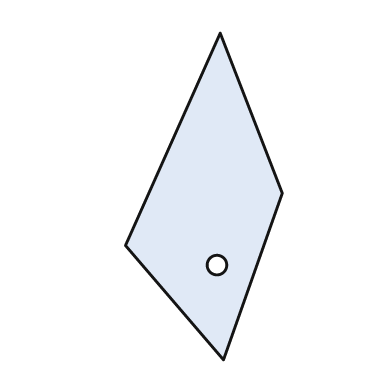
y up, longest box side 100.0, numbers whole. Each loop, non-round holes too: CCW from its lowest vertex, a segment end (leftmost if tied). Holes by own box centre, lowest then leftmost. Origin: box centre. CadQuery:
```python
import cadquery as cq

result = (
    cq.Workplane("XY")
    .moveTo(6.0, -50.0)
    .lineTo(24.0, 1.0)
    .lineTo(5.0, 50.0)
    .lineTo(-24.0, -15.0)
    .close()
    .moveTo(4.0, -21.0)
    .circle(3.0)
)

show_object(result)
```